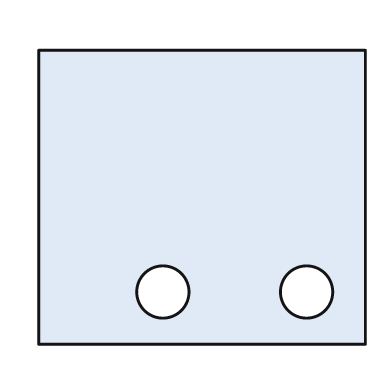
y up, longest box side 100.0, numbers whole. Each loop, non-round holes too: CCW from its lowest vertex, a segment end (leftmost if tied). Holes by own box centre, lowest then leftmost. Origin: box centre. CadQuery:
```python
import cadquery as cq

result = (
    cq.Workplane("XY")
    .moveTo(-50.0, -45.0)
    .lineTo(50.0, -45.0)
    .lineTo(50.0, 45.0)
    .lineTo(-50.0, 45.0)
    .close()
    .moveTo(-12.0, -29.0)
    .circle(8.0)
    .moveTo(32.0, -29.0)
    .circle(8.0)
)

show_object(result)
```